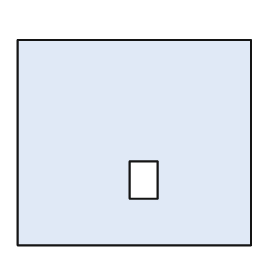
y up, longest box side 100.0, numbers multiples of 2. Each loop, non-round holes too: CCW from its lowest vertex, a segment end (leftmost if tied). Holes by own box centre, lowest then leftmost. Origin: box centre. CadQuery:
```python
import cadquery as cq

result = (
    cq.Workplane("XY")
    .moveTo(-50.0, -44.0)
    .lineTo(50.0, -44.0)
    .lineTo(50.0, 44.0)
    .lineTo(-50.0, 44.0)
    .close()
    .moveTo(-2.0, -24.0)
    .lineTo(10.0, -24.0)
    .lineTo(10.0, -8.0)
    .lineTo(-2.0, -8.0)
    .close()
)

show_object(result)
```